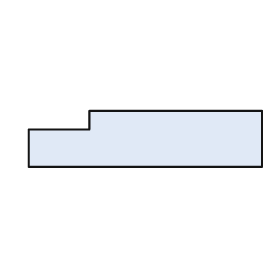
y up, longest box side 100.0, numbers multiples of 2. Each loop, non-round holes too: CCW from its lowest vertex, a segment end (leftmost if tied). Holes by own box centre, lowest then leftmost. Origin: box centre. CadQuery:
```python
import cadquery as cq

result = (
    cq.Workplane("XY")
    .moveTo(-50.0, -12.0)
    .lineTo(50.0, -12.0)
    .lineTo(50.0, 12.0)
    .lineTo(-24.0, 12.0)
    .lineTo(-24.0, 4.0)
    .lineTo(-50.0, 4.0)
    .close()
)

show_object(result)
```